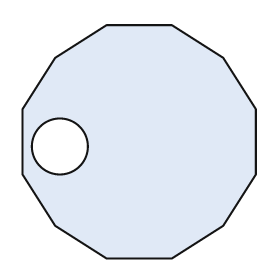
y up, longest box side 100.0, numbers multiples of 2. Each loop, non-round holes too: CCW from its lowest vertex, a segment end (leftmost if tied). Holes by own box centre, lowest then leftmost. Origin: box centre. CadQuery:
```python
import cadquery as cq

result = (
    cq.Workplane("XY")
    .moveTo(-14.0, -50.0)
    .lineTo(14.0, -50.0)
    .lineTo(36.0, -36.0)
    .lineTo(50.0, -14.0)
    .lineTo(50.0, 14.0)
    .lineTo(36.0, 36.0)
    .lineTo(14.0, 50.0)
    .lineTo(-14.0, 50.0)
    .lineTo(-36.0, 36.0)
    .lineTo(-50.0, 14.0)
    .lineTo(-50.0, -14.0)
    .lineTo(-36.0, -36.0)
    .close()
    .moveTo(-34.0, -2.0)
    .circle(12.0)
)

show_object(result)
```